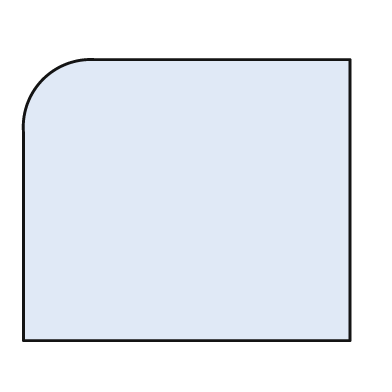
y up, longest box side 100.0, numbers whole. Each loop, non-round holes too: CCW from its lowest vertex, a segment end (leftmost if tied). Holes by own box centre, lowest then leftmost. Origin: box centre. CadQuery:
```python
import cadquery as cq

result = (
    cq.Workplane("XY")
    .moveTo(-50.0, -43.0)
    .lineTo(50.0, -43.0)
    .lineTo(50.0, 43.0)
    .lineTo(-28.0, 43.0)
    .threePointArc((-44.0, 37.0), (-50.0, 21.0))
    .close()
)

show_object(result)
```